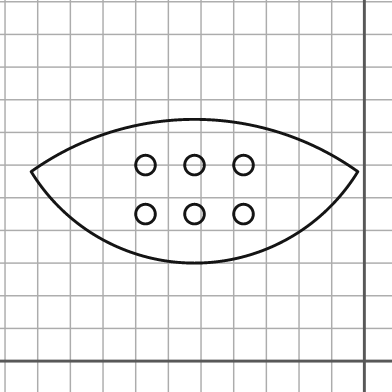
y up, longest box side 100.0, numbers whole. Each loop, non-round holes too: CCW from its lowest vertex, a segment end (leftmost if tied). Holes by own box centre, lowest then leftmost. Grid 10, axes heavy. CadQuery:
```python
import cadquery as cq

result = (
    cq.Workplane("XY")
    .moveTo(-102.0, 58.0)
    .threePointArc((-52.0, 30.0), (-2.0, 58.0))
    .threePointArc((-52.0, 74.0), (-102.0, 58.0))
    .close()
    .moveTo(-67.0, 45.0)
    .circle(3.0)
    .moveTo(-52.0, 45.0)
    .circle(3.0)
    .moveTo(-37.0, 45.0)
    .circle(3.0)
    .moveTo(-67.0, 60.0)
    .circle(3.0)
    .moveTo(-52.0, 60.0)
    .circle(3.0)
    .moveTo(-37.0, 60.0)
    .circle(3.0)
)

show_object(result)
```